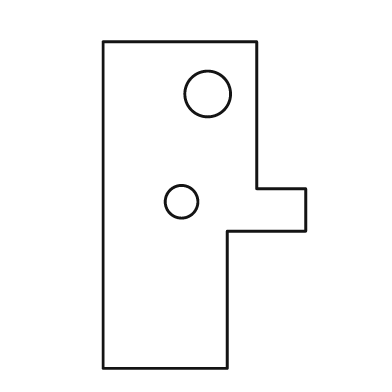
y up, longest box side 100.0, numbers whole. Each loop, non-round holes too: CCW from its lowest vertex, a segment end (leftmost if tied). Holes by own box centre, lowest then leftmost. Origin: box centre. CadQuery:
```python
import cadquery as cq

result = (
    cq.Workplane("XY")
    .moveTo(-31.0, -50.0)
    .lineTo(7.0, -50.0)
    .lineTo(7.0, -8.0)
    .lineTo(31.0, -8.0)
    .lineTo(31.0, 5.0)
    .lineTo(16.0, 5.0)
    .lineTo(16.0, 50.0)
    .lineTo(-31.0, 50.0)
    .close()
    .moveTo(-7.0, 1.0)
    .circle(5.0)
    .moveTo(1.0, 34.0)
    .circle(7.0)
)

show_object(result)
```